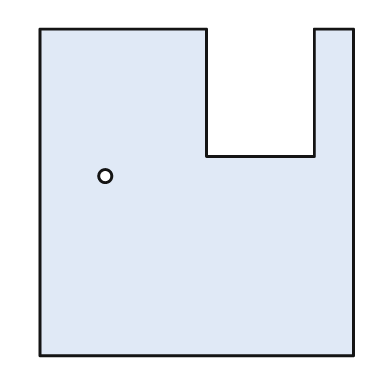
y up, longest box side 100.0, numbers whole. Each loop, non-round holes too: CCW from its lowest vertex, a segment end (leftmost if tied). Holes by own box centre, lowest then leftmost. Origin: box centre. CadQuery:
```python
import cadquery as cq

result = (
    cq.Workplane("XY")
    .moveTo(-48.0, -50.0)
    .lineTo(48.0, -50.0)
    .lineTo(48.0, 50.0)
    .lineTo(36.0, 50.0)
    .lineTo(36.0, 11.0)
    .lineTo(3.0, 11.0)
    .lineTo(3.0, 50.0)
    .lineTo(-48.0, 50.0)
    .close()
    .moveTo(-28.0, 5.0)
    .circle(2.0)
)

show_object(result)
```